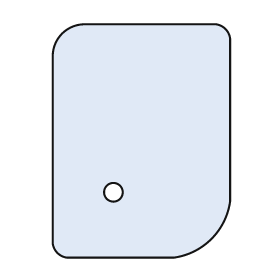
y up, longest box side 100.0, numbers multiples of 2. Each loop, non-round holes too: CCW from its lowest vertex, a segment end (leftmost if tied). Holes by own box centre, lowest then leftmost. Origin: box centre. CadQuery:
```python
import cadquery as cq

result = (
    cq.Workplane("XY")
    .moveTo(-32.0, -50.0)
    .lineTo(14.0, -50.0)
    .threePointArc((30.0, -42.0), (38.0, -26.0))
    .lineTo(38.0, 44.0)
    .threePointArc((36.0, 48.0), (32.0, 50.0))
    .lineTo(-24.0, 50.0)
    .threePointArc((-34.0, 46.0), (-38.0, 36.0))
    .lineTo(-38.0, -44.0)
    .threePointArc((-36.0, -48.0), (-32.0, -50.0))
    .close()
    .moveTo(-12.0, -22.0)
    .circle(4.0)
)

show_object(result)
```